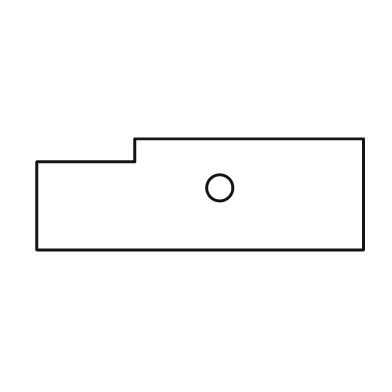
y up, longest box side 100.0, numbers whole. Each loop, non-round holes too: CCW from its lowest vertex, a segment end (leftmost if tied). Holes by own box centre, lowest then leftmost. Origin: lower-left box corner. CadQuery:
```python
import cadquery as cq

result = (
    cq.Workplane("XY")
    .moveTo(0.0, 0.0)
    .lineTo(100.0, 0.0)
    .lineTo(100.0, 34.0)
    .lineTo(30.0, 34.0)
    .lineTo(30.0, 27.0)
    .lineTo(0.0, 27.0)
    .close()
    .moveTo(56.0, 19.0)
    .circle(4.0)
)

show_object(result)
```